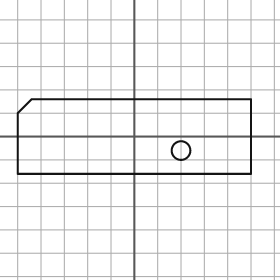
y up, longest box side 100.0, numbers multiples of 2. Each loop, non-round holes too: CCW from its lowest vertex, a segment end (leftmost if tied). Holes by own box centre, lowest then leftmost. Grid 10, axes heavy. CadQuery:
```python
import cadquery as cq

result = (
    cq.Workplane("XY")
    .moveTo(-50.0, -16.0)
    .lineTo(50.0, -16.0)
    .lineTo(50.0, 16.0)
    .lineTo(-44.0, 16.0)
    .lineTo(-50.0, 10.0)
    .close()
    .moveTo(20.0, -6.0)
    .circle(4.0)
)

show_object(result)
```